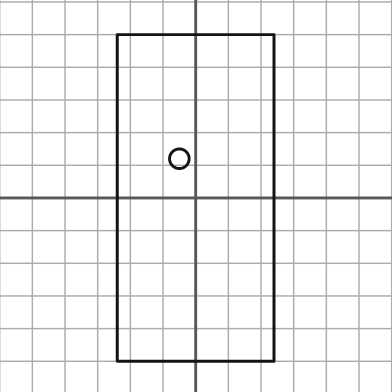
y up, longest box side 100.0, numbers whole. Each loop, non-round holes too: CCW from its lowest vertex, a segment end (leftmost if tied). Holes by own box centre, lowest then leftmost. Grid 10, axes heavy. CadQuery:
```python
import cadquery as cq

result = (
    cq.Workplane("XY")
    .moveTo(-24.0, -50.0)
    .lineTo(24.0, -50.0)
    .lineTo(24.0, 50.0)
    .lineTo(-24.0, 50.0)
    .close()
    .moveTo(-5.0, 12.0)
    .circle(3.0)
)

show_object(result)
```